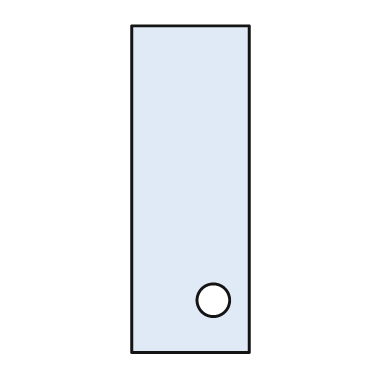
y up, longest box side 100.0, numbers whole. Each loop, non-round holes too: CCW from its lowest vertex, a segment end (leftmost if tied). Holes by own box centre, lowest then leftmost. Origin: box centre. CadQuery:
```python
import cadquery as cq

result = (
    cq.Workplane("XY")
    .moveTo(-18.0, -50.0)
    .lineTo(18.0, -50.0)
    .lineTo(18.0, 50.0)
    .lineTo(-18.0, 50.0)
    .close()
    .moveTo(7.0, -34.0)
    .circle(5.0)
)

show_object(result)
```